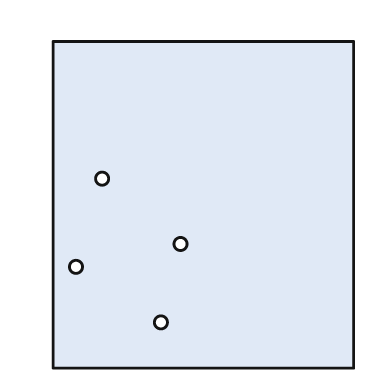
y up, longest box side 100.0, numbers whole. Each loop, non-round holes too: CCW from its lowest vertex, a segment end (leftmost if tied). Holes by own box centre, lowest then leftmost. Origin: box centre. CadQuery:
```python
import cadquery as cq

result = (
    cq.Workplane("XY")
    .moveTo(-46.0, -50.0)
    .lineTo(46.0, -50.0)
    .lineTo(46.0, 50.0)
    .lineTo(-46.0, 50.0)
    .close()
    .moveTo(-13.0, -36.0)
    .circle(2.0)
    .moveTo(-39.0, -19.0)
    .circle(2.0)
    .moveTo(-7.0, -12.0)
    .circle(2.0)
    .moveTo(-31.0, 8.0)
    .circle(2.0)
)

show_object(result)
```